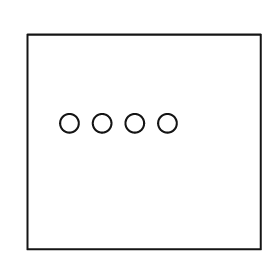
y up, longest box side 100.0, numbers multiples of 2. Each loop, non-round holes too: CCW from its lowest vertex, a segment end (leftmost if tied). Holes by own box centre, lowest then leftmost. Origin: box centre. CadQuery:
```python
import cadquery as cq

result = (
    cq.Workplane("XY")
    .moveTo(-50.0, -46.0)
    .lineTo(50.0, -46.0)
    .lineTo(50.0, 46.0)
    .lineTo(-50.0, 46.0)
    .close()
    .moveTo(-32.0, 8.0)
    .circle(4.0)
    .moveTo(-18.0, 8.0)
    .circle(4.0)
    .moveTo(-4.0, 8.0)
    .circle(4.0)
    .moveTo(10.0, 8.0)
    .circle(4.0)
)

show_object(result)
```